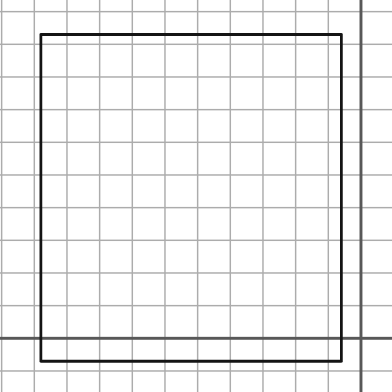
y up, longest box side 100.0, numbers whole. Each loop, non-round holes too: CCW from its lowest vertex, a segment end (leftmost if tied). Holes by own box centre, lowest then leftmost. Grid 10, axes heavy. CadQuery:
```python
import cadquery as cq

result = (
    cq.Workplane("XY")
    .moveTo(-98.0, -7.0)
    .lineTo(-6.0, -7.0)
    .lineTo(-6.0, 93.0)
    .lineTo(-98.0, 93.0)
    .close()
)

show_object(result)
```